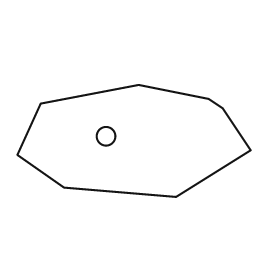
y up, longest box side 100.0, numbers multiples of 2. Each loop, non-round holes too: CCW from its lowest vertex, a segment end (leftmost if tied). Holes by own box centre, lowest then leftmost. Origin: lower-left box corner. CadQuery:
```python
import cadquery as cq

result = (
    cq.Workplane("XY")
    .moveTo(68.0, 0.0)
    .lineTo(100.0, 20.0)
    .lineTo(88.0, 38.0)
    .lineTo(82.0, 42.0)
    .lineTo(52.0, 48.0)
    .lineTo(10.0, 40.0)
    .lineTo(0.0, 18.0)
    .lineTo(20.0, 4.0)
    .close()
    .moveTo(38.0, 26.0)
    .circle(4.0)
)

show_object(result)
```